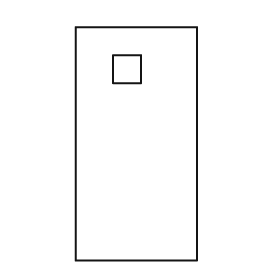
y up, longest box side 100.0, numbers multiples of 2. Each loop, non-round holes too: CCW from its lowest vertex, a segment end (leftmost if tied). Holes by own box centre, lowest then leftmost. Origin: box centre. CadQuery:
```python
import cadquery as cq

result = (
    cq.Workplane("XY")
    .moveTo(-26.0, -50.0)
    .lineTo(26.0, -50.0)
    .lineTo(26.0, 50.0)
    .lineTo(-26.0, 50.0)
    .close()
    .moveTo(-10.0, 26.0)
    .lineTo(2.0, 26.0)
    .lineTo(2.0, 38.0)
    .lineTo(-10.0, 38.0)
    .close()
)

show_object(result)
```